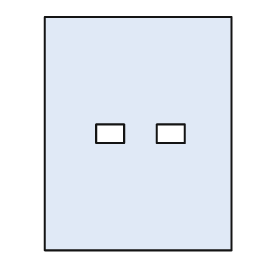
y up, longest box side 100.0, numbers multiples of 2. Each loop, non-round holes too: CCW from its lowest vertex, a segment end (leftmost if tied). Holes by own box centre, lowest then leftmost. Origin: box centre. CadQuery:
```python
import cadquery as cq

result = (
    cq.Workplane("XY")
    .moveTo(-40.0, -50.0)
    .lineTo(40.0, -50.0)
    .lineTo(40.0, 50.0)
    .lineTo(-40.0, 50.0)
    .close()
    .moveTo(-18.0, -4.0)
    .lineTo(-6.0, -4.0)
    .lineTo(-6.0, 4.0)
    .lineTo(-18.0, 4.0)
    .close()
    .moveTo(8.0, -4.0)
    .lineTo(20.0, -4.0)
    .lineTo(20.0, 4.0)
    .lineTo(8.0, 4.0)
    .close()
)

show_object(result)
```